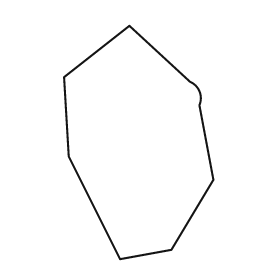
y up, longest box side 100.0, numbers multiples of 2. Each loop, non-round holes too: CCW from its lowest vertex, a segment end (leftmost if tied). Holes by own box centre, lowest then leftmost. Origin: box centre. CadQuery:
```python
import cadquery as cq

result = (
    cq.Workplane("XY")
    .moveTo(-8.0, -50.0)
    .lineTo(14.0, -46.0)
    .lineTo(32.0, -16.0)
    .lineTo(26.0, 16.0)
    .threePointArc((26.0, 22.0), (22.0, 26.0))
    .lineTo(-4.0, 50.0)
    .lineTo(-32.0, 28.0)
    .lineTo(-30.0, -6.0)
    .close()
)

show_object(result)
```